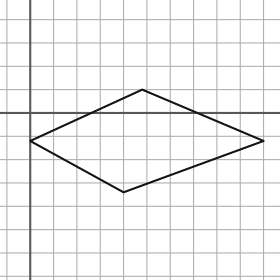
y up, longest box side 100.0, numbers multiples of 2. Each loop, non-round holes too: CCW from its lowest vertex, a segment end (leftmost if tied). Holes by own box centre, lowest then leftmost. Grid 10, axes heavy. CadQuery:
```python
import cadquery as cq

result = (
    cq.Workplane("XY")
    .moveTo(40.0, -34.0)
    .lineTo(100.0, -12.0)
    .lineTo(48.0, 10.0)
    .lineTo(0.0, -12.0)
    .close()
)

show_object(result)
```